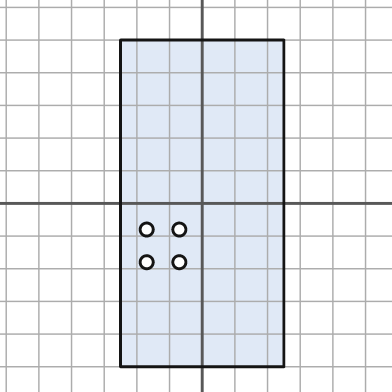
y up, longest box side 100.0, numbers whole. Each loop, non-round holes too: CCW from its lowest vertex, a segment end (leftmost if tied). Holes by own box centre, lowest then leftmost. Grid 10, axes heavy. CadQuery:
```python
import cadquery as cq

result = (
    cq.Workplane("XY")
    .moveTo(-25.0, -50.0)
    .lineTo(25.0, -50.0)
    .lineTo(25.0, 50.0)
    .lineTo(-25.0, 50.0)
    .close()
    .moveTo(-17.0, -18.0)
    .circle(2.0)
    .moveTo(-7.0, -18.0)
    .circle(2.0)
    .moveTo(-17.0, -8.0)
    .circle(2.0)
    .moveTo(-7.0, -8.0)
    .circle(2.0)
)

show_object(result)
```